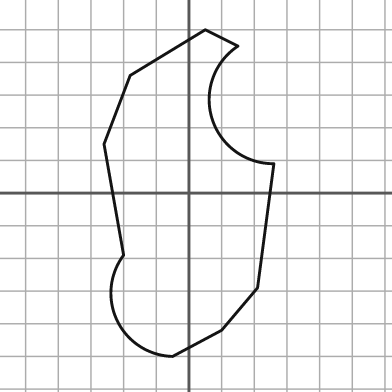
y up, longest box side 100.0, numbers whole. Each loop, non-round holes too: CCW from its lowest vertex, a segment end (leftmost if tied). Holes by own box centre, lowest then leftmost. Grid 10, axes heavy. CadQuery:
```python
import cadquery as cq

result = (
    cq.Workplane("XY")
    .moveTo(-5.0, -50.0)
    .lineTo(10.0, -42.0)
    .lineTo(21.0, -29.0)
    .lineTo(26.0, 9.0)
    .threePointArc((7.0, 23.0), (15.0, 45.0))
    .lineTo(5.0, 50.0)
    .lineTo(-18.0, 36.0)
    .lineTo(-26.0, 15.0)
    .lineTo(-20.0, -19.0)
    .threePointArc((-22.0, -39.0), (-5.0, -50.0))
    .close()
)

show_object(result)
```